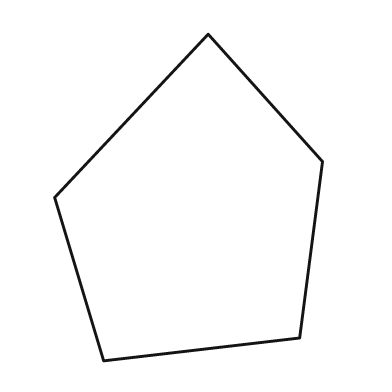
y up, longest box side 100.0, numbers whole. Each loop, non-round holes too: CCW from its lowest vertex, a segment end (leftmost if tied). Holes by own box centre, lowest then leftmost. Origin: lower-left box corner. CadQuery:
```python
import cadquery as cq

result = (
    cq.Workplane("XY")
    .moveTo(15.0, 0.0)
    .lineTo(75.0, 7.0)
    .lineTo(82.0, 61.0)
    .lineTo(47.0, 100.0)
    .lineTo(0.0, 50.0)
    .close()
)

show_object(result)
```